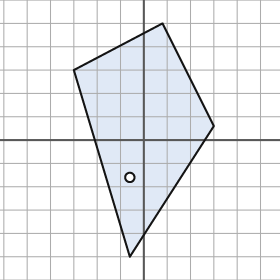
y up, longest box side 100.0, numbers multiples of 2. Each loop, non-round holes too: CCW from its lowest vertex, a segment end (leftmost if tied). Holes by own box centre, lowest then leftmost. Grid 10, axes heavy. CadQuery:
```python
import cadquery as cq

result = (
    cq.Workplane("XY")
    .moveTo(-6.0, -50.0)
    .lineTo(30.0, 6.0)
    .lineTo(8.0, 50.0)
    .lineTo(-30.0, 30.0)
    .close()
    .moveTo(-6.0, -16.0)
    .circle(2.0)
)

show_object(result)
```